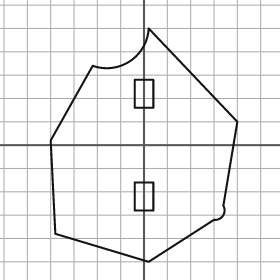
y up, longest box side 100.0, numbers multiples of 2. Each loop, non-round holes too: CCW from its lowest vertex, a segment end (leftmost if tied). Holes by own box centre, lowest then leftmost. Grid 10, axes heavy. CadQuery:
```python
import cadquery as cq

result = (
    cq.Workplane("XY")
    .moveTo(2.0, -50.0)
    .lineTo(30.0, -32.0)
    .threePointArc((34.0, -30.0), (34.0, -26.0))
    .lineTo(40.0, 10.0)
    .lineTo(2.0, 50.0)
    .threePointArc((-6.0, 36.0), (-22.0, 34.0))
    .lineTo(-40.0, 2.0)
    .lineTo(-38.0, -38.0)
    .close()
    .moveTo(-4.0, -28.0)
    .lineTo(4.0, -28.0)
    .lineTo(4.0, -16.0)
    .lineTo(-4.0, -16.0)
    .close()
    .moveTo(-4.0, 16.0)
    .lineTo(4.0, 16.0)
    .lineTo(4.0, 28.0)
    .lineTo(-4.0, 28.0)
    .close()
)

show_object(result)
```